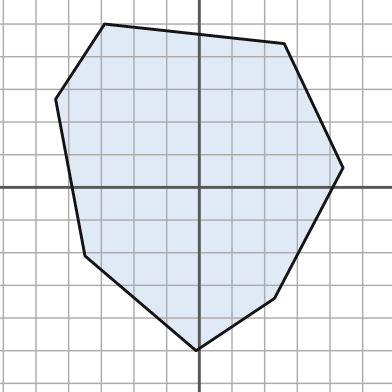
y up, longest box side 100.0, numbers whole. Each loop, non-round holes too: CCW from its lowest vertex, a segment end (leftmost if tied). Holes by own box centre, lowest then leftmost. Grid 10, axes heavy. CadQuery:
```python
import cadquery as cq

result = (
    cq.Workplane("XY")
    .moveTo(-1.0, -50.0)
    .lineTo(23.0, -34.0)
    .lineTo(44.0, 6.0)
    .lineTo(26.0, 44.0)
    .lineTo(-29.0, 50.0)
    .lineTo(-44.0, 27.0)
    .lineTo(-35.0, -21.0)
    .close()
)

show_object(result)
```